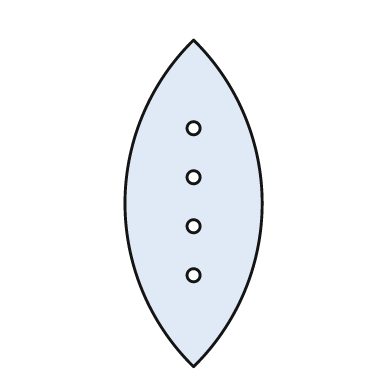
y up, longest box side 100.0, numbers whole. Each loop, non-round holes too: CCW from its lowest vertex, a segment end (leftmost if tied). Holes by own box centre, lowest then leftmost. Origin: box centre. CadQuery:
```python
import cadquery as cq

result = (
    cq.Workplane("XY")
    .moveTo(0.0, -50.0)
    .threePointArc((21.0, 0.0), (0.0, 50.0))
    .threePointArc((-21.0, 0.0), (0.0, -50.0))
    .close()
    .moveTo(0.0, -22.0)
    .circle(2.0)
    .moveTo(0.0, -7.0)
    .circle(2.0)
    .moveTo(0.0, 8.0)
    .circle(2.0)
    .moveTo(0.0, 23.0)
    .circle(2.0)
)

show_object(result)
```